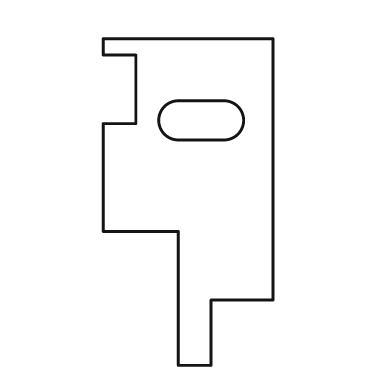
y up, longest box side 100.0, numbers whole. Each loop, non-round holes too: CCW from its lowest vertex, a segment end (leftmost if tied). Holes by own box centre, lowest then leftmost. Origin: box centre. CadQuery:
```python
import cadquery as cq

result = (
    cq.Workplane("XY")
    .moveTo(-3.0, -50.0)
    .lineTo(7.0, -50.0)
    .lineTo(7.0, -30.0)
    .lineTo(26.0, -30.0)
    .lineTo(26.0, 50.0)
    .lineTo(-26.0, 50.0)
    .lineTo(-26.0, 45.0)
    .lineTo(-16.0, 45.0)
    .lineTo(-16.0, 24.0)
    .lineTo(-26.0, 24.0)
    .lineTo(-26.0, -9.0)
    .lineTo(-3.0, -9.0)
    .close()
    .moveTo(-3.0, 19.0)
    .lineTo(11.0, 19.0)
    .threePointArc((17.0, 25.0), (11.0, 31.0))
    .lineTo(-3.0, 31.0)
    .threePointArc((-9.0, 25.0), (-3.0, 19.0))
    .close()
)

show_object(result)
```